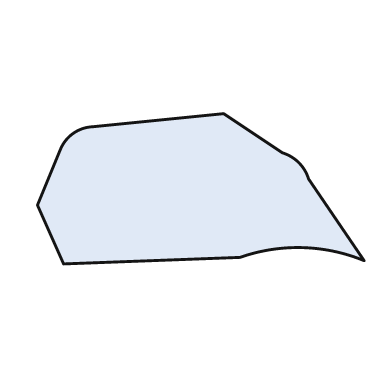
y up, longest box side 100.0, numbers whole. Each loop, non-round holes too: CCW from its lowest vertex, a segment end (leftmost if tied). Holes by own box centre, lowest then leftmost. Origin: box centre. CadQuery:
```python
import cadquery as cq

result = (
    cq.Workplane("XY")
    .moveTo(-42.0, -23.0)
    .lineTo(12.0, -21.0)
    .threePointArc((31.0, -18.0), (50.0, -22.0))
    .lineTo(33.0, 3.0)
    .threePointArc((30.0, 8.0), (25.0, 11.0))
    .lineTo(7.0, 23.0)
    .lineTo(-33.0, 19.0)
    .threePointArc((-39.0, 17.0), (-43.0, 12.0))
    .lineTo(-50.0, -5.0)
    .close()
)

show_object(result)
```